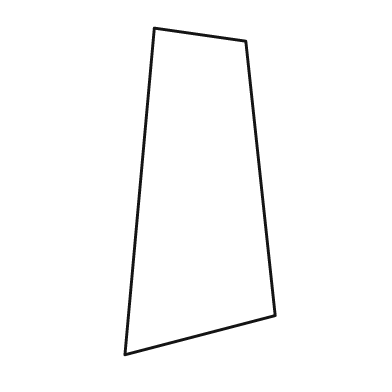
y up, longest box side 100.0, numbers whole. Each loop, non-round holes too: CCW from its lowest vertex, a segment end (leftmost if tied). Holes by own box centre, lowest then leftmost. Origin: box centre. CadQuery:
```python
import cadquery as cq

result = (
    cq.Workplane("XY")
    .moveTo(-23.0, -50.0)
    .lineTo(23.0, -38.0)
    .lineTo(14.0, 46.0)
    .lineTo(-14.0, 50.0)
    .close()
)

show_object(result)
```